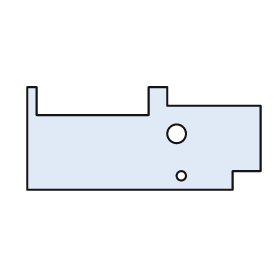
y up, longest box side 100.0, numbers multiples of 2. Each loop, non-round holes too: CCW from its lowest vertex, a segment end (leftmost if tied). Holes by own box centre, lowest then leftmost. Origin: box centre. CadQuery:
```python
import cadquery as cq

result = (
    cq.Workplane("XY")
    .moveTo(-50.0, -22.0)
    .lineTo(38.0, -22.0)
    .lineTo(38.0, -14.0)
    .lineTo(50.0, -14.0)
    .lineTo(50.0, 14.0)
    .lineTo(10.0, 14.0)
    .lineTo(10.0, 22.0)
    .lineTo(2.0, 22.0)
    .lineTo(2.0, 10.0)
    .lineTo(-46.0, 10.0)
    .lineTo(-46.0, 22.0)
    .lineTo(-50.0, 22.0)
    .close()
    .moveTo(16.0, -16.0)
    .circle(2.0)
    .moveTo(14.0, 2.0)
    .circle(4.0)
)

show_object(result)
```